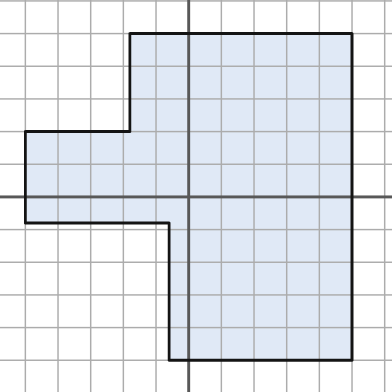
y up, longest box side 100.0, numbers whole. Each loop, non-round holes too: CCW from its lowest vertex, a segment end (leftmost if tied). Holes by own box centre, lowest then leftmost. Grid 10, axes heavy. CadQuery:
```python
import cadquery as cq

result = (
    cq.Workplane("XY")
    .moveTo(-6.0, -50.0)
    .lineTo(50.0, -50.0)
    .lineTo(50.0, 50.0)
    .lineTo(-18.0, 50.0)
    .lineTo(-18.0, 20.0)
    .lineTo(-50.0, 20.0)
    .lineTo(-50.0, -8.0)
    .lineTo(-6.0, -8.0)
    .close()
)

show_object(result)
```